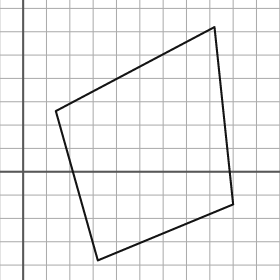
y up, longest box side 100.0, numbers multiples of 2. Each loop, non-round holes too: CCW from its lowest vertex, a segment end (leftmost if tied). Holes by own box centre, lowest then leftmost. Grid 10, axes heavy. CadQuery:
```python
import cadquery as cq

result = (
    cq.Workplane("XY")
    .moveTo(32.0, -38.0)
    .lineTo(90.0, -14.0)
    .lineTo(82.0, 62.0)
    .lineTo(14.0, 26.0)
    .close()
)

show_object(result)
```